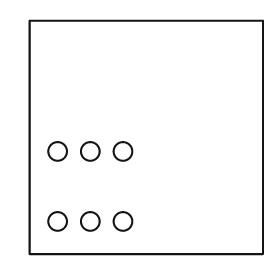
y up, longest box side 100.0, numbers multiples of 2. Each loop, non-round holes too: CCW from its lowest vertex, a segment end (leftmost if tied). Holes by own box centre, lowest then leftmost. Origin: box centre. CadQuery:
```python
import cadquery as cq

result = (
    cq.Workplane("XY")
    .moveTo(-50.0, -50.0)
    .lineTo(50.0, -50.0)
    .lineTo(50.0, 50.0)
    .lineTo(-50.0, 50.0)
    .close()
    .moveTo(-38.0, -36.0)
    .circle(4.0)
    .moveTo(-24.0, -36.0)
    .circle(4.0)
    .moveTo(-10.0, -36.0)
    .circle(4.0)
    .moveTo(-38.0, -6.0)
    .circle(4.0)
    .moveTo(-24.0, -6.0)
    .circle(4.0)
    .moveTo(-10.0, -6.0)
    .circle(4.0)
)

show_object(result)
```